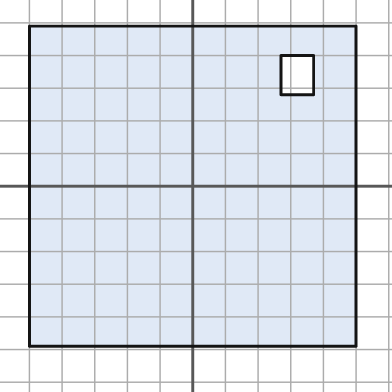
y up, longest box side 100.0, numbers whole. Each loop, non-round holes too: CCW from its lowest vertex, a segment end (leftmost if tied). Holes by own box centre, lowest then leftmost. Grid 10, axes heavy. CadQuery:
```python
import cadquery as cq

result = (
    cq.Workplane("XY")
    .moveTo(-50.0, -49.0)
    .lineTo(50.0, -49.0)
    .lineTo(50.0, 49.0)
    .lineTo(-50.0, 49.0)
    .close()
    .moveTo(27.0, 28.0)
    .lineTo(37.0, 28.0)
    .lineTo(37.0, 40.0)
    .lineTo(27.0, 40.0)
    .close()
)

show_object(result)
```